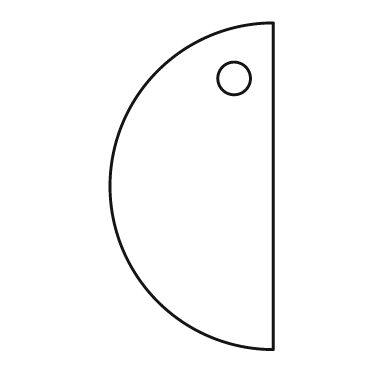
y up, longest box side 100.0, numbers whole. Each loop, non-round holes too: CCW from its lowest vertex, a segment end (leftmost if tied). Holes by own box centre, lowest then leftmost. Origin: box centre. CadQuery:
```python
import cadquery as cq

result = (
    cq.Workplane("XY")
    .moveTo(25.0, -50.0)
    .lineTo(25.0, 50.0)
    .threePointArc((-25.0, 0.0), (25.0, -50.0))
    .close()
    .moveTo(13.0, 33.0)
    .circle(5.0)
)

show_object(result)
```